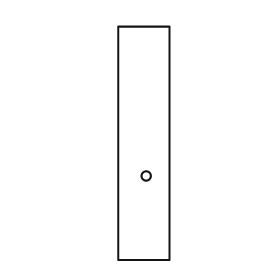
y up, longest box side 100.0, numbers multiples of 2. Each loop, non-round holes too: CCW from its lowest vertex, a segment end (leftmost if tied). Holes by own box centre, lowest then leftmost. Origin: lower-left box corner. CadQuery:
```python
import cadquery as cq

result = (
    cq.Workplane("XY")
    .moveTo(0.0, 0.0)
    .lineTo(22.0, 0.0)
    .lineTo(22.0, 100.0)
    .lineTo(0.0, 100.0)
    .close()
    .moveTo(12.0, 36.0)
    .circle(2.0)
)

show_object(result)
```